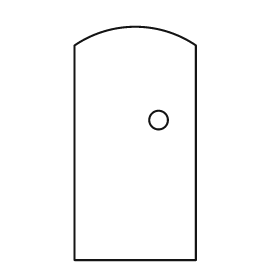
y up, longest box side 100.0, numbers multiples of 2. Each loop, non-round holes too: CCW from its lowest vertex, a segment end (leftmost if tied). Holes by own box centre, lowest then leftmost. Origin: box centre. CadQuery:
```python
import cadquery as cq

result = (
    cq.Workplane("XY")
    .moveTo(-26.0, -50.0)
    .lineTo(26.0, -50.0)
    .lineTo(26.0, 42.0)
    .threePointArc((0.0, 50.0), (-26.0, 42.0))
    .close()
    .moveTo(10.0, 10.0)
    .circle(4.0)
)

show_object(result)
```